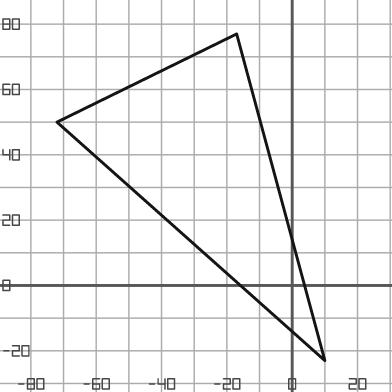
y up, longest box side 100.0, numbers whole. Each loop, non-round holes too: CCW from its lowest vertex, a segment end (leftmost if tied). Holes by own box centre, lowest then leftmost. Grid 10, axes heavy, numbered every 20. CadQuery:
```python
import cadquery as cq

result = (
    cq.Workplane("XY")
    .moveTo(10.0, -23.0)
    .lineTo(-17.0, 77.0)
    .lineTo(-72.0, 50.0)
    .close()
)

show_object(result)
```